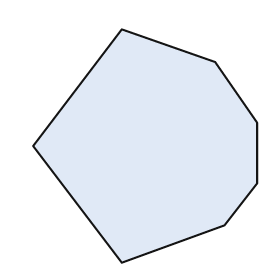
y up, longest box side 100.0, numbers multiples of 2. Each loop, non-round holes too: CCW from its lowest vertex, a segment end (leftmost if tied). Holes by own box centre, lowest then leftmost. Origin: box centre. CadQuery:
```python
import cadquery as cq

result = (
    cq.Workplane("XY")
    .moveTo(-10.0, -50.0)
    .lineTo(34.0, -34.0)
    .lineTo(48.0, -16.0)
    .lineTo(48.0, 10.0)
    .lineTo(30.0, 36.0)
    .lineTo(-10.0, 50.0)
    .lineTo(-48.0, 0.0)
    .close()
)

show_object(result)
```